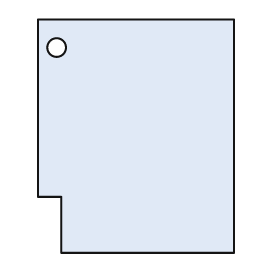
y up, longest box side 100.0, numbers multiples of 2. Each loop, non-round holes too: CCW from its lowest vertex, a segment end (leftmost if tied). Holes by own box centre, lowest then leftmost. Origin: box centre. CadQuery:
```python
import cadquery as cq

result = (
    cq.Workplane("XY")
    .moveTo(-32.0, -50.0)
    .lineTo(42.0, -50.0)
    .lineTo(42.0, 50.0)
    .lineTo(-42.0, 50.0)
    .lineTo(-42.0, -26.0)
    .lineTo(-32.0, -26.0)
    .close()
    .moveTo(-34.0, 38.0)
    .circle(4.0)
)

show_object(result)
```